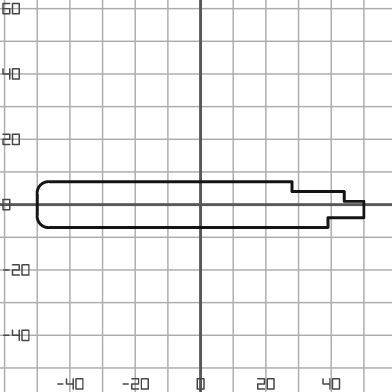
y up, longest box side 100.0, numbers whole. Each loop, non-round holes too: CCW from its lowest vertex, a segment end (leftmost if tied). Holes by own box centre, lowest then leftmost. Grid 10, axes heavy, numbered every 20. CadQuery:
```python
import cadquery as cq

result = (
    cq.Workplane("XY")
    .moveTo(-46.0, -7.0)
    .lineTo(39.0, -7.0)
    .lineTo(39.0, -4.0)
    .lineTo(50.0, -4.0)
    .lineTo(50.0, 1.0)
    .lineTo(44.0, 1.0)
    .lineTo(44.0, 4.0)
    .lineTo(28.0, 4.0)
    .lineTo(28.0, 7.0)
    .lineTo(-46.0, 7.0)
    .threePointArc((-49.0, 6.0), (-50.0, 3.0))
    .lineTo(-50.0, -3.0)
    .threePointArc((-49.0, -6.0), (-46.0, -7.0))
    .close()
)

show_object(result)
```